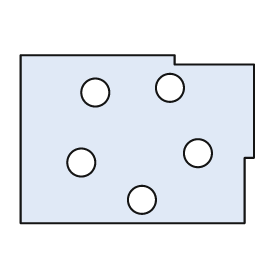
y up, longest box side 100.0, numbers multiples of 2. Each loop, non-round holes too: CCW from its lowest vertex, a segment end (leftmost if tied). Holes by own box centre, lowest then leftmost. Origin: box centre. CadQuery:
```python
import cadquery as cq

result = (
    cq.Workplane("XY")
    .moveTo(-50.0, -36.0)
    .lineTo(46.0, -36.0)
    .lineTo(46.0, -8.0)
    .lineTo(50.0, -8.0)
    .lineTo(50.0, 32.0)
    .lineTo(16.0, 32.0)
    .lineTo(16.0, 36.0)
    .lineTo(-50.0, 36.0)
    .close()
    .moveTo(2.0, -26.0)
    .circle(6.0)
    .moveTo(-24.0, -10.0)
    .circle(6.0)
    .moveTo(26.0, -6.0)
    .circle(6.0)
    .moveTo(-18.0, 20.0)
    .circle(6.0)
    .moveTo(14.0, 22.0)
    .circle(6.0)
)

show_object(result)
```